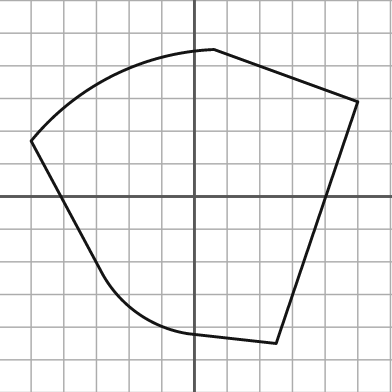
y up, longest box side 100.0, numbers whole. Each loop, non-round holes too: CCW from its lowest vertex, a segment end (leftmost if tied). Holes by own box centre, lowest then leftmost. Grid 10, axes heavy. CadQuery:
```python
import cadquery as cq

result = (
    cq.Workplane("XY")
    .moveTo(25.0, -45.0)
    .lineTo(50.0, 29.0)
    .lineTo(6.0, 45.0)
    .threePointArc((-25.0, 37.0), (-50.0, 17.0))
    .lineTo(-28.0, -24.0)
    .threePointArc((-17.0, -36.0), (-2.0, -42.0))
    .close()
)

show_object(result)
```